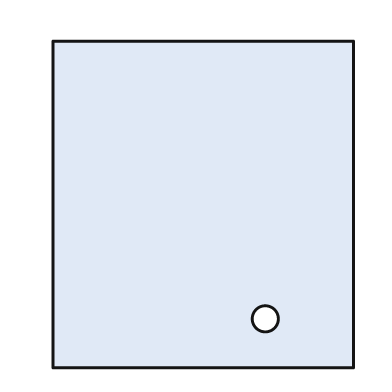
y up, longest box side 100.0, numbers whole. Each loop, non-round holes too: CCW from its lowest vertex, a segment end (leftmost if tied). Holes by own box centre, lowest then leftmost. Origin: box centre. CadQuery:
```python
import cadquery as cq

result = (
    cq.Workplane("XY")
    .moveTo(-46.0, -50.0)
    .lineTo(46.0, -50.0)
    .lineTo(46.0, 50.0)
    .lineTo(-46.0, 50.0)
    .close()
    .moveTo(19.0, -35.0)
    .circle(4.0)
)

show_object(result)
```